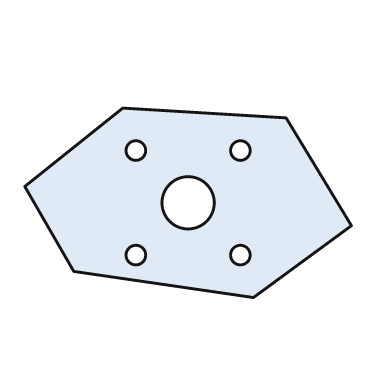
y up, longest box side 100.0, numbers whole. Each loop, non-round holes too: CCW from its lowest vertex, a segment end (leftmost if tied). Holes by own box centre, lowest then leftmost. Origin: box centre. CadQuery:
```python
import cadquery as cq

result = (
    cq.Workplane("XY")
    .moveTo(20.0, -29.0)
    .lineTo(50.0, -7.0)
    .lineTo(30.0, 26.0)
    .lineTo(-20.0, 29.0)
    .lineTo(-50.0, 5.0)
    .lineTo(-35.0, -21.0)
    .close()
    .moveTo(-16.0, -16.0)
    .circle(3.0)
    .moveTo(16.0, -16.0)
    .circle(3.0)
    .moveTo(0.0, 0.0)
    .circle(8.0)
    .moveTo(-16.0, 16.0)
    .circle(3.0)
    .moveTo(16.0, 16.0)
    .circle(3.0)
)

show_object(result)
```